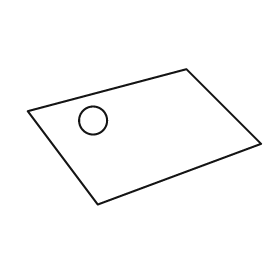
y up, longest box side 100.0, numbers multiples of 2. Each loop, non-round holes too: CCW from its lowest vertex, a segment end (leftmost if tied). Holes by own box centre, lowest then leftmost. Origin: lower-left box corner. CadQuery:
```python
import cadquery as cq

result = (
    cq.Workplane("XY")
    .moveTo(30.0, 0.0)
    .lineTo(100.0, 26.0)
    .lineTo(68.0, 58.0)
    .lineTo(0.0, 40.0)
    .close()
    .moveTo(28.0, 36.0)
    .circle(6.0)
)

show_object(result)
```